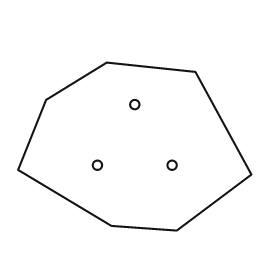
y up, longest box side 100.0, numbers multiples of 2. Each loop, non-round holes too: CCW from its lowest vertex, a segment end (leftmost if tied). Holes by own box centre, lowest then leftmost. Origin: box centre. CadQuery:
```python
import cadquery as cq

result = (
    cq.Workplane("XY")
    .moveTo(18.0, -36.0)
    .lineTo(50.0, -12.0)
    .lineTo(26.0, 32.0)
    .lineTo(-12.0, 36.0)
    .lineTo(-38.0, 20.0)
    .lineTo(-50.0, -10.0)
    .lineTo(-10.0, -34.0)
    .close()
    .moveTo(-16.0, -8.0)
    .circle(2.0)
    .moveTo(16.0, -8.0)
    .circle(2.0)
    .moveTo(0.0, 18.0)
    .circle(2.0)
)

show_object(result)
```